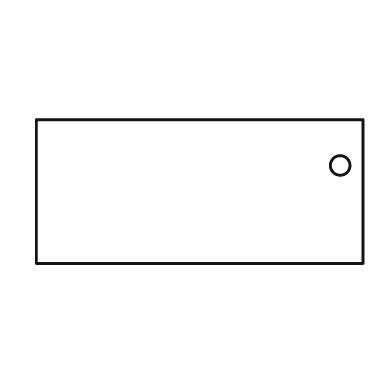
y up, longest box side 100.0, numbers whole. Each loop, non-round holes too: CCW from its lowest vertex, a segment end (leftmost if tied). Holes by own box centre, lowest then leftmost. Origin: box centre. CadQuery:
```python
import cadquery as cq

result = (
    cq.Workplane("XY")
    .moveTo(-50.0, -22.0)
    .lineTo(50.0, -22.0)
    .lineTo(50.0, 22.0)
    .lineTo(-50.0, 22.0)
    .close()
    .moveTo(43.0, 8.0)
    .circle(3.0)
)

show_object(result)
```